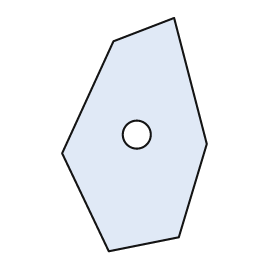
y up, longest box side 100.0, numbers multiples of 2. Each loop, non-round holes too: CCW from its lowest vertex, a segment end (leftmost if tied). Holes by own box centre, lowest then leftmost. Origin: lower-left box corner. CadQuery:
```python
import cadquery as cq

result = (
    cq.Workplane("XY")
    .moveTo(20.0, 0.0)
    .lineTo(50.0, 6.0)
    .lineTo(62.0, 46.0)
    .lineTo(48.0, 100.0)
    .lineTo(22.0, 90.0)
    .lineTo(0.0, 42.0)
    .close()
    .moveTo(32.0, 50.0)
    .circle(6.0)
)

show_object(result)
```